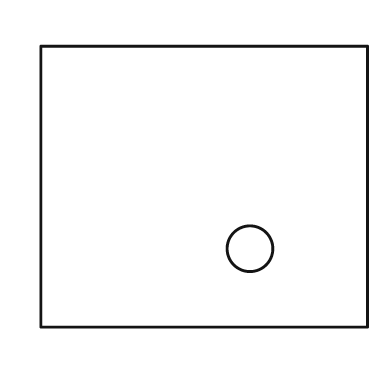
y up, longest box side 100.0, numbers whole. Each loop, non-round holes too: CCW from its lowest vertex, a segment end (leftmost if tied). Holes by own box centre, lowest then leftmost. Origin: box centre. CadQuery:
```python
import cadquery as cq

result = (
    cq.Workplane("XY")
    .moveTo(-50.0, -43.0)
    .lineTo(50.0, -43.0)
    .lineTo(50.0, 43.0)
    .lineTo(-50.0, 43.0)
    .close()
    .moveTo(14.0, -19.0)
    .circle(7.0)
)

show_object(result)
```